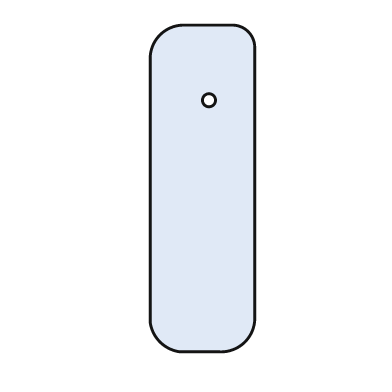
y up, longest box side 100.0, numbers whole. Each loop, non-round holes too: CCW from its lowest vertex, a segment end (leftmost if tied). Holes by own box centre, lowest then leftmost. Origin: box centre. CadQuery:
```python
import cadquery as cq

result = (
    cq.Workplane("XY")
    .moveTo(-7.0, -50.0)
    .lineTo(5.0, -50.0)
    .threePointArc((13.0, -47.0), (16.0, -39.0))
    .lineTo(16.0, 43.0)
    .threePointArc((14.0, 48.0), (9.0, 50.0))
    .lineTo(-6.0, 50.0)
    .threePointArc((-13.0, 47.0), (-16.0, 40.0))
    .lineTo(-16.0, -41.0)
    .threePointArc((-13.0, -47.0), (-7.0, -50.0))
    .close()
    .moveTo(2.0, 27.0)
    .circle(2.0)
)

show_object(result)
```